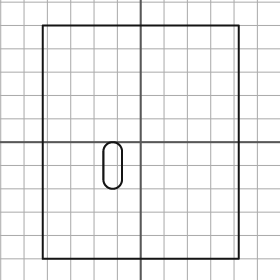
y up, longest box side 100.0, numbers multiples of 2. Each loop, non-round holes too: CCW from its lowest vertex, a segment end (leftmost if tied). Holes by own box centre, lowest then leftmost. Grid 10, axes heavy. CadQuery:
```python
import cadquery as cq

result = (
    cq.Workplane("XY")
    .moveTo(-42.0, -50.0)
    .lineTo(42.0, -50.0)
    .lineTo(42.0, 50.0)
    .lineTo(-42.0, 50.0)
    .close()
    .moveTo(-16.0, -16.0)
    .threePointArc((-12.0, -20.0), (-8.0, -16.0))
    .lineTo(-8.0, -4.0)
    .threePointArc((-12.0, 0.0), (-16.0, -4.0))
    .close()
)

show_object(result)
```